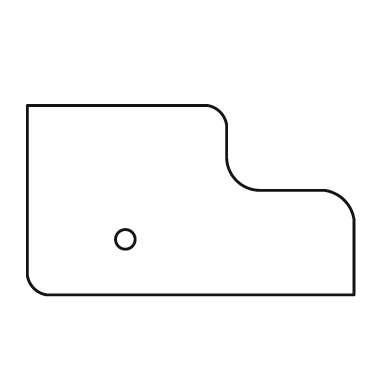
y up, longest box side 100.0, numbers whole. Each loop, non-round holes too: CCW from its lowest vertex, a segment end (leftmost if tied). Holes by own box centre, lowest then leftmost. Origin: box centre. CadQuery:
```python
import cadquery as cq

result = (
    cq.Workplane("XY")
    .moveTo(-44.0, -29.0)
    .lineTo(50.0, -29.0)
    .lineTo(50.0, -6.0)
    .threePointArc((47.0, 0.0), (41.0, 3.0))
    .lineTo(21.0, 3.0)
    .threePointArc((14.0, 6.0), (11.0, 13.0))
    .lineTo(11.0, 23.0)
    .threePointArc((9.0, 27.0), (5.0, 29.0))
    .lineTo(-50.0, 29.0)
    .lineTo(-50.0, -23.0)
    .threePointArc((-48.0, -27.0), (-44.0, -29.0))
    .close()
    .moveTo(-20.0, -12.0)
    .circle(3.0)
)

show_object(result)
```